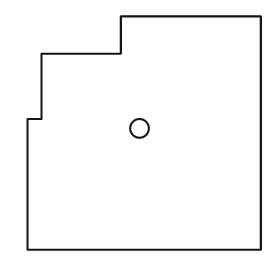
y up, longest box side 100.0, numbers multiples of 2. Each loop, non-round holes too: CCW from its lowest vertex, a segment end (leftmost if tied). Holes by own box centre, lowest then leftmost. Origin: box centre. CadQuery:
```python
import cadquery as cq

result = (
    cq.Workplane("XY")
    .moveTo(-50.0, -50.0)
    .lineTo(50.0, -50.0)
    .lineTo(50.0, 50.0)
    .lineTo(-10.0, 50.0)
    .lineTo(-10.0, 34.0)
    .lineTo(-44.0, 34.0)
    .lineTo(-44.0, 6.0)
    .lineTo(-50.0, 6.0)
    .close()
    .moveTo(-2.0, 2.0)
    .circle(4.0)
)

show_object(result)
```